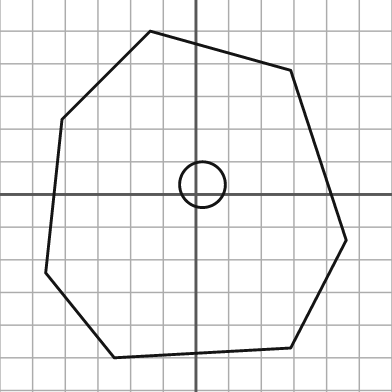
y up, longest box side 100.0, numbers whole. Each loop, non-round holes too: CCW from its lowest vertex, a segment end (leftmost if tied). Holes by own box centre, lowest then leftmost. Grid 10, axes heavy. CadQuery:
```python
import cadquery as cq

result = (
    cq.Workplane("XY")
    .moveTo(-25.0, -50.0)
    .lineTo(29.0, -47.0)
    .lineTo(46.0, -14.0)
    .lineTo(29.0, 38.0)
    .lineTo(-14.0, 50.0)
    .lineTo(-41.0, 23.0)
    .lineTo(-46.0, -24.0)
    .close()
    .moveTo(2.0, 3.0)
    .circle(7.0)
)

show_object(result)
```